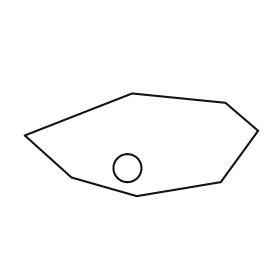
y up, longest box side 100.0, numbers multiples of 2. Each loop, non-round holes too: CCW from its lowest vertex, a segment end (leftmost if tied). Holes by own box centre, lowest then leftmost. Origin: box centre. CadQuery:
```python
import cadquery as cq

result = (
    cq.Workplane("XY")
    .moveTo(-2.0, -22.0)
    .lineTo(34.0, -16.0)
    .lineTo(50.0, 6.0)
    .lineTo(36.0, 18.0)
    .lineTo(-4.0, 22.0)
    .lineTo(-50.0, 4.0)
    .lineTo(-30.0, -14.0)
    .close()
    .moveTo(-6.0, -10.0)
    .circle(6.0)
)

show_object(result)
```